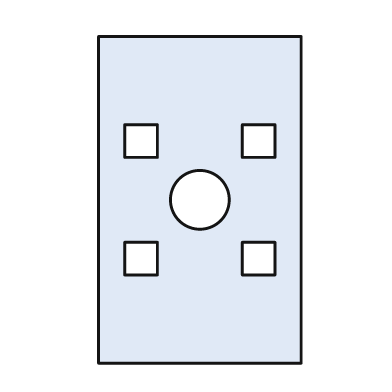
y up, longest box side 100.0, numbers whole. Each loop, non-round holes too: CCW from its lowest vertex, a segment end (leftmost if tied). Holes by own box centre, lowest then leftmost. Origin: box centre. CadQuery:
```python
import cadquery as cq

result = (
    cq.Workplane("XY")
    .moveTo(-31.0, -50.0)
    .lineTo(31.0, -50.0)
    .lineTo(31.0, 50.0)
    .lineTo(-31.0, 50.0)
    .close()
    .moveTo(-23.0, -23.0)
    .lineTo(-13.0, -23.0)
    .lineTo(-13.0, -13.0)
    .lineTo(-23.0, -13.0)
    .close()
    .moveTo(13.0, -23.0)
    .lineTo(23.0, -23.0)
    .lineTo(23.0, -13.0)
    .lineTo(13.0, -13.0)
    .close()
    .moveTo(0.0, 0.0)
    .circle(9.0)
    .moveTo(-23.0, 13.0)
    .lineTo(-13.0, 13.0)
    .lineTo(-13.0, 23.0)
    .lineTo(-23.0, 23.0)
    .close()
    .moveTo(13.0, 13.0)
    .lineTo(23.0, 13.0)
    .lineTo(23.0, 23.0)
    .lineTo(13.0, 23.0)
    .close()
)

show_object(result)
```